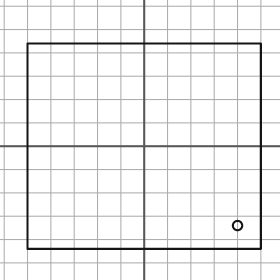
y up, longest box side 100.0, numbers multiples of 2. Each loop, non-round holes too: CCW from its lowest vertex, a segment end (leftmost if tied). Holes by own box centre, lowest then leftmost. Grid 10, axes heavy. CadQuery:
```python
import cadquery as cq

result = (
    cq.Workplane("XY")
    .moveTo(-50.0, -44.0)
    .lineTo(50.0, -44.0)
    .lineTo(50.0, 44.0)
    .lineTo(-50.0, 44.0)
    .close()
    .moveTo(40.0, -34.0)
    .circle(2.0)
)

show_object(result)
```